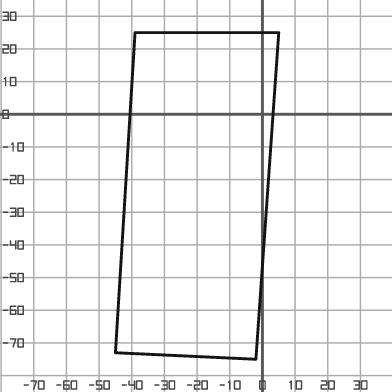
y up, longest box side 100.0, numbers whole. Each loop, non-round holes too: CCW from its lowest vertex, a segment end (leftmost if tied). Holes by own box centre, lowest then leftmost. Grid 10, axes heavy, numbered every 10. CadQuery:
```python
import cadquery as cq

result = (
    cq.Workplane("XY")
    .moveTo(-2.0, -75.0)
    .lineTo(5.0, 25.0)
    .lineTo(-39.0, 25.0)
    .lineTo(-45.0, -73.0)
    .close()
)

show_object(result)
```